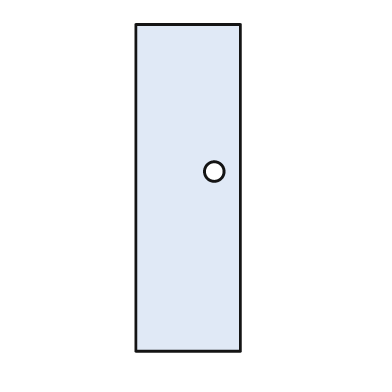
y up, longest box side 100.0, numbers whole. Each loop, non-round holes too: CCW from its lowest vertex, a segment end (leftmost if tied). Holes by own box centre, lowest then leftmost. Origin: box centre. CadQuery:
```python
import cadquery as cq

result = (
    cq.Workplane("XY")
    .moveTo(-16.0, -50.0)
    .lineTo(16.0, -50.0)
    .lineTo(16.0, 50.0)
    .lineTo(-16.0, 50.0)
    .close()
    .moveTo(8.0, 5.0)
    .circle(3.0)
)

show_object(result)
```